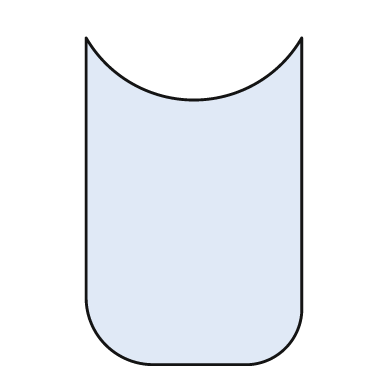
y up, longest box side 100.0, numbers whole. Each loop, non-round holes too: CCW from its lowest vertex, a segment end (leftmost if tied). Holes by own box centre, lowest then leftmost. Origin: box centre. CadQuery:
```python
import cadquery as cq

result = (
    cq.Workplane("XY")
    .moveTo(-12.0, -50.0)
    .lineTo(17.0, -50.0)
    .threePointArc((28.0, -45.0), (33.0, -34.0))
    .lineTo(33.0, 50.0)
    .threePointArc((0.0, 31.0), (-33.0, 50.0))
    .lineTo(-33.0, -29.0)
    .threePointArc((-27.0, -44.0), (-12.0, -50.0))
    .close()
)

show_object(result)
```